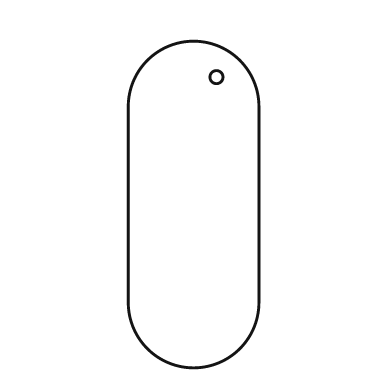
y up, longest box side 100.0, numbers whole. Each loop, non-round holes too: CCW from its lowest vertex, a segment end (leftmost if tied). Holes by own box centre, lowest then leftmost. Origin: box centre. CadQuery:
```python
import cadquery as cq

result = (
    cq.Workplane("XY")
    .moveTo(-20.0, -30.0)
    .threePointArc((0.0, -50.0), (20.0, -30.0))
    .lineTo(20.0, 30.0)
    .threePointArc((0.0, 50.0), (-20.0, 30.0))
    .close()
    .moveTo(7.0, 39.0)
    .circle(2.0)
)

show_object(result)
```